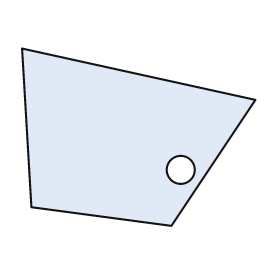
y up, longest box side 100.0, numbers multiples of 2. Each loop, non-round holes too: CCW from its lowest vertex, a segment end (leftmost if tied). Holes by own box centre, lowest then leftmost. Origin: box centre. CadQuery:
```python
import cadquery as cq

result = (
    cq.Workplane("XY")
    .moveTo(14.0, -38.0)
    .lineTo(50.0, 16.0)
    .lineTo(-50.0, 38.0)
    .lineTo(-46.0, -30.0)
    .close()
    .moveTo(18.0, -14.0)
    .circle(6.0)
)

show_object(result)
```